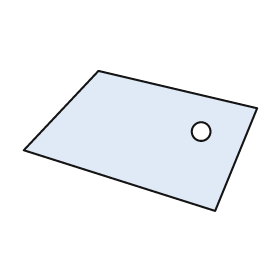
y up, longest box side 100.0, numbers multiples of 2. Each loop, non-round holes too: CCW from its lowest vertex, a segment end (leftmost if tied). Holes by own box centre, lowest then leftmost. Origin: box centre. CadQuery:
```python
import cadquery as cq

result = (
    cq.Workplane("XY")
    .moveTo(32.0, -30.0)
    .lineTo(50.0, 14.0)
    .lineTo(-18.0, 30.0)
    .lineTo(-50.0, -4.0)
    .close()
    .moveTo(26.0, 4.0)
    .circle(4.0)
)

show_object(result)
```